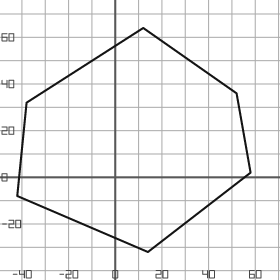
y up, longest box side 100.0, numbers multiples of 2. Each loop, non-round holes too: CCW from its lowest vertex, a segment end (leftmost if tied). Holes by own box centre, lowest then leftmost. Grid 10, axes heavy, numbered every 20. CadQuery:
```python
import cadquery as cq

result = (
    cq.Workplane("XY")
    .moveTo(14.0, -32.0)
    .lineTo(58.0, 2.0)
    .lineTo(52.0, 36.0)
    .lineTo(12.0, 64.0)
    .lineTo(-38.0, 32.0)
    .lineTo(-42.0, -8.0)
    .close()
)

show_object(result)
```